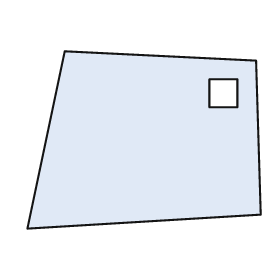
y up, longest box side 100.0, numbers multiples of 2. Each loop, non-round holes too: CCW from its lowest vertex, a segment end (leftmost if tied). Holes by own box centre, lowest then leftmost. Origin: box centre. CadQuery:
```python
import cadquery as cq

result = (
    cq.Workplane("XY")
    .moveTo(-50.0, -38.0)
    .lineTo(50.0, -32.0)
    .lineTo(48.0, 34.0)
    .lineTo(-34.0, 38.0)
    .close()
    .moveTo(28.0, 14.0)
    .lineTo(40.0, 14.0)
    .lineTo(40.0, 26.0)
    .lineTo(28.0, 26.0)
    .close()
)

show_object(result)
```